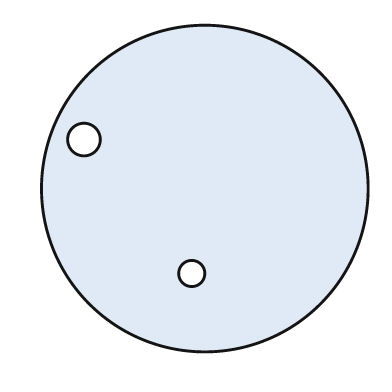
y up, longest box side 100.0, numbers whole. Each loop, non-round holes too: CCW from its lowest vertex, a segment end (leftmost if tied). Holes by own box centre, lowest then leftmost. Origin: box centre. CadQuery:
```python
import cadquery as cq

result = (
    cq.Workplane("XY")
    .moveTo(0.0, 0.0)
    .circle(50.0)
    .moveTo(-4.0, -26.0)
    .circle(4.0)
    .moveTo(-37.0, 15.0)
    .circle(5.0)
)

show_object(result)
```